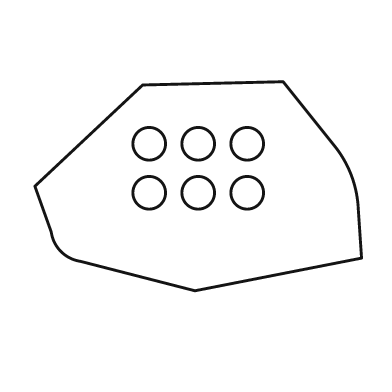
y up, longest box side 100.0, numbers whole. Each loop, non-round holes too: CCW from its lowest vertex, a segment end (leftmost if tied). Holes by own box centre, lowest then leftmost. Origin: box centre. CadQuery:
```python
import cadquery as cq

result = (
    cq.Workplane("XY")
    .moveTo(-1.0, -32.0)
    .lineTo(50.0, -22.0)
    .lineTo(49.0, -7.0)
    .threePointArc((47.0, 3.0), (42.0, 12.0))
    .lineTo(26.0, 32.0)
    .lineTo(-17.0, 31.0)
    .lineTo(-50.0, 0.0)
    .lineTo(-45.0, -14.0)
    .threePointArc((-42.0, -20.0), (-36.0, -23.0))
    .close()
    .moveTo(-15.0, -2.0)
    .circle(5.0)
    .moveTo(0.0, -2.0)
    .circle(5.0)
    .moveTo(15.0, -2.0)
    .circle(5.0)
    .moveTo(-15.0, 13.0)
    .circle(5.0)
    .moveTo(0.0, 13.0)
    .circle(5.0)
    .moveTo(15.0, 13.0)
    .circle(5.0)
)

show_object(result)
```